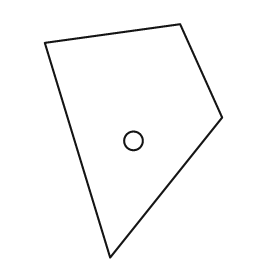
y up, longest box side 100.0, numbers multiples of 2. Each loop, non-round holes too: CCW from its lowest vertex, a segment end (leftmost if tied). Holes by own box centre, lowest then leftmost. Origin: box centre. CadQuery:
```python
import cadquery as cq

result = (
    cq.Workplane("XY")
    .moveTo(-10.0, -50.0)
    .lineTo(38.0, 10.0)
    .lineTo(20.0, 50.0)
    .lineTo(-38.0, 42.0)
    .close()
    .moveTo(0.0, 0.0)
    .circle(4.0)
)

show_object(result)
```